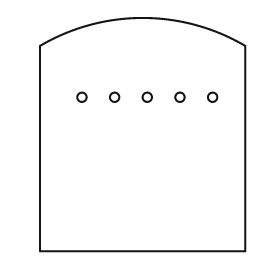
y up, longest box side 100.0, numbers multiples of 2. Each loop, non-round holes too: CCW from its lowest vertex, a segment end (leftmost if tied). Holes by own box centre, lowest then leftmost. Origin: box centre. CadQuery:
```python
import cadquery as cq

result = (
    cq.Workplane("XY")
    .moveTo(-44.0, -50.0)
    .lineTo(44.0, -50.0)
    .lineTo(44.0, 38.0)
    .threePointArc((0.0, 50.0), (-44.0, 38.0))
    .close()
    .moveTo(-26.0, 16.0)
    .circle(2.0)
    .moveTo(-12.0, 16.0)
    .circle(2.0)
    .moveTo(2.0, 16.0)
    .circle(2.0)
    .moveTo(16.0, 16.0)
    .circle(2.0)
    .moveTo(30.0, 16.0)
    .circle(2.0)
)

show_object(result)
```